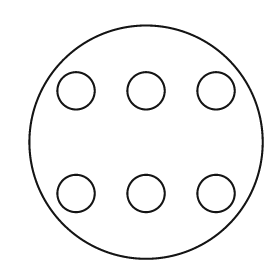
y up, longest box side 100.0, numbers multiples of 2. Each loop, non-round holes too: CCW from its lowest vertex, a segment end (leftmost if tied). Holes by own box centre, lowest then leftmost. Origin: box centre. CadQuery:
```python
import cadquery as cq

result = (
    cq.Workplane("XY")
    .moveTo(0.0, 0.0)
    .circle(50.0)
    .moveTo(-30.0, -22.0)
    .circle(8.0)
    .moveTo(0.0, -22.0)
    .circle(8.0)
    .moveTo(30.0, -22.0)
    .circle(8.0)
    .moveTo(-30.0, 22.0)
    .circle(8.0)
    .moveTo(0.0, 22.0)
    .circle(8.0)
    .moveTo(30.0, 22.0)
    .circle(8.0)
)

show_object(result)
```